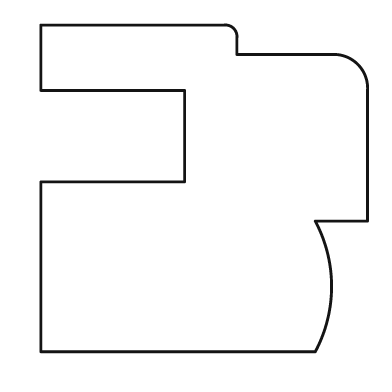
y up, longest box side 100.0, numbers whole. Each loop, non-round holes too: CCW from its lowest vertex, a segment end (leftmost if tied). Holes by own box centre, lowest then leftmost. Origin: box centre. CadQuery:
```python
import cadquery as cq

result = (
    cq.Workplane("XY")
    .moveTo(-50.0, -50.0)
    .lineTo(34.0, -50.0)
    .threePointArc((39.0, -30.0), (34.0, -10.0))
    .lineTo(50.0, -10.0)
    .lineTo(50.0, 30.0)
    .threePointArc((47.0, 38.0), (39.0, 41.0))
    .lineTo(10.0, 41.0)
    .lineTo(10.0, 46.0)
    .threePointArc((9.0, 49.0), (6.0, 50.0))
    .lineTo(-50.0, 50.0)
    .lineTo(-50.0, 30.0)
    .lineTo(-6.0, 30.0)
    .lineTo(-6.0, 2.0)
    .lineTo(-50.0, 2.0)
    .close()
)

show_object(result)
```